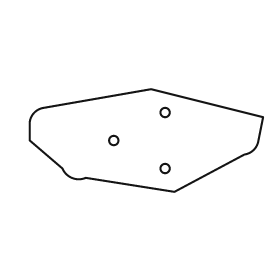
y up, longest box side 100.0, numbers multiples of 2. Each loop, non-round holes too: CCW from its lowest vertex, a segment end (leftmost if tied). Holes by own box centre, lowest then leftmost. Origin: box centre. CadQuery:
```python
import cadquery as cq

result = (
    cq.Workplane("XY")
    .moveTo(12.0, -22.0)
    .lineTo(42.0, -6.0)
    .threePointArc((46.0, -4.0), (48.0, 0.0))
    .lineTo(50.0, 10.0)
    .lineTo(2.0, 22.0)
    .lineTo(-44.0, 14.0)
    .threePointArc((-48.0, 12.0), (-50.0, 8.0))
    .lineTo(-50.0, 0.0)
    .lineTo(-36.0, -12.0)
    .threePointArc((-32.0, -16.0), (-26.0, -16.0))
    .close()
    .moveTo(8.0, -12.0)
    .circle(2.0)
    .moveTo(-14.0, 0.0)
    .circle(2.0)
    .moveTo(8.0, 12.0)
    .circle(2.0)
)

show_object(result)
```